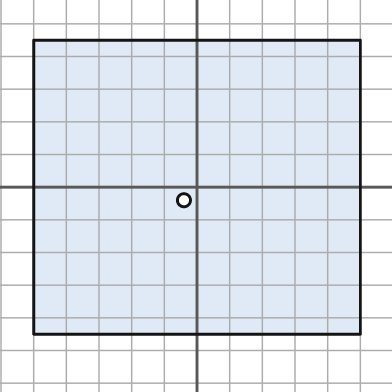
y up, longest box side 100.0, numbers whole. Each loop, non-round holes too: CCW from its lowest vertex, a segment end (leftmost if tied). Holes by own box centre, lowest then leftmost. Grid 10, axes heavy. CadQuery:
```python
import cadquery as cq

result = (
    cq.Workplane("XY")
    .moveTo(-50.0, -45.0)
    .lineTo(50.0, -45.0)
    .lineTo(50.0, 45.0)
    .lineTo(-50.0, 45.0)
    .close()
    .moveTo(-4.0, -4.0)
    .circle(2.0)
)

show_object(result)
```